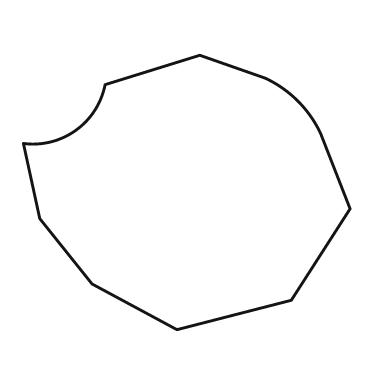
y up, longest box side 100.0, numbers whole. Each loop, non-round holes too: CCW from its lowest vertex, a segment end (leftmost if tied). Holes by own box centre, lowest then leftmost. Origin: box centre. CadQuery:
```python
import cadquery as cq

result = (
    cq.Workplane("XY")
    .moveTo(-3.0, -42.0)
    .lineTo(32.0, -33.0)
    .lineTo(50.0, -5.0)
    .lineTo(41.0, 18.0)
    .threePointArc((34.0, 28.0), (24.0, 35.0))
    .lineTo(4.0, 42.0)
    .lineTo(-25.0, 33.0)
    .threePointArc((-34.0, 19.0), (-50.0, 15.0))
    .lineTo(-45.0, -8.0)
    .lineTo(-29.0, -28.0)
    .close()
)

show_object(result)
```